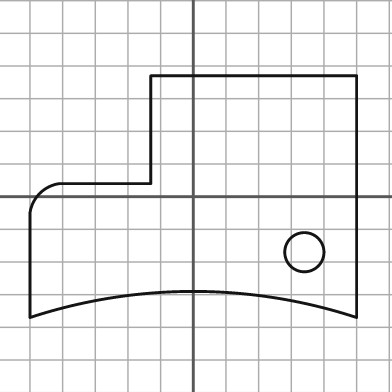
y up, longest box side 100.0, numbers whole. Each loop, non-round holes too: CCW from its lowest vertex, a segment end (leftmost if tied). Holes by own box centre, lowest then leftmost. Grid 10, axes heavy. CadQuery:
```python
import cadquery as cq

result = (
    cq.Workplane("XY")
    .moveTo(-50.0, -37.0)
    .threePointArc((0.0, -29.0), (50.0, -37.0))
    .lineTo(50.0, 37.0)
    .lineTo(-13.0, 37.0)
    .lineTo(-13.0, 4.0)
    .lineTo(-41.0, 4.0)
    .threePointArc((-47.0, 1.0), (-50.0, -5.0))
    .close()
    .moveTo(34.0, -17.0)
    .circle(6.0)
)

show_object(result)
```